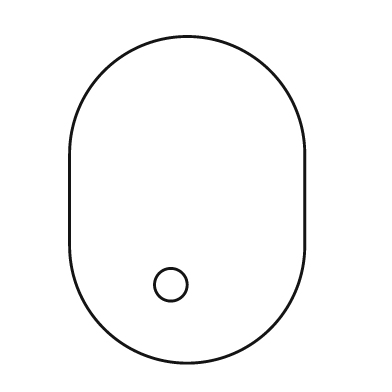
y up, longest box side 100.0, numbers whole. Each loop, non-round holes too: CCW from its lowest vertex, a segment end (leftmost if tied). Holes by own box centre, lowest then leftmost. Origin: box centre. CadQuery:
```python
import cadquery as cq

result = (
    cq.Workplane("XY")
    .moveTo(-36.0, -14.0)
    .threePointArc((0.0, -50.0), (36.0, -14.0))
    .lineTo(36.0, 14.0)
    .threePointArc((0.0, 50.0), (-36.0, 14.0))
    .close()
    .moveTo(-5.0, -26.0)
    .circle(5.0)
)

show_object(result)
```